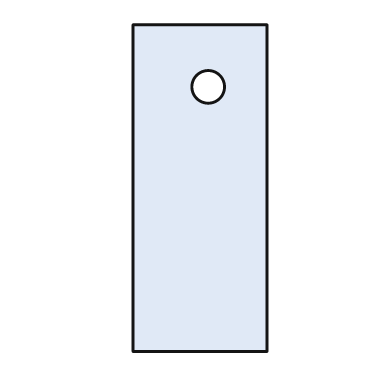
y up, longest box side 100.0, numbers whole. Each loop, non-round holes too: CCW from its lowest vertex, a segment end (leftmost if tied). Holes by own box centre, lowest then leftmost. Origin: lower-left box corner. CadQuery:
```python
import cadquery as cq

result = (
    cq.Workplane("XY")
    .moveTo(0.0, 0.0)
    .lineTo(41.0, 0.0)
    .lineTo(41.0, 100.0)
    .lineTo(0.0, 100.0)
    .close()
    .moveTo(23.0, 81.0)
    .circle(5.0)
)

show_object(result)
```